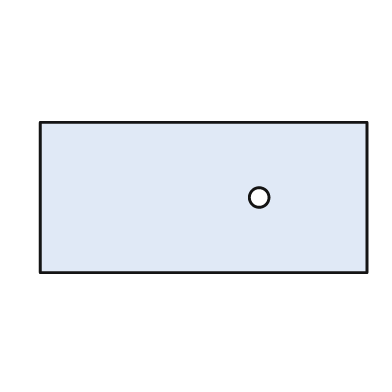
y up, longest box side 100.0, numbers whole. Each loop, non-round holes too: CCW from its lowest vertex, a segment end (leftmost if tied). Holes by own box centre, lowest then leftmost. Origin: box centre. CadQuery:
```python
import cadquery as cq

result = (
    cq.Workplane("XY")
    .moveTo(-50.0, -23.0)
    .lineTo(50.0, -23.0)
    .lineTo(50.0, 23.0)
    .lineTo(-50.0, 23.0)
    .close()
    .moveTo(17.0, 0.0)
    .circle(3.0)
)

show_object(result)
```